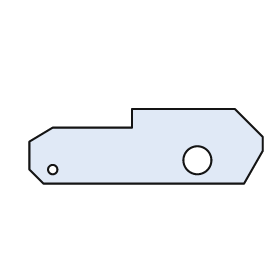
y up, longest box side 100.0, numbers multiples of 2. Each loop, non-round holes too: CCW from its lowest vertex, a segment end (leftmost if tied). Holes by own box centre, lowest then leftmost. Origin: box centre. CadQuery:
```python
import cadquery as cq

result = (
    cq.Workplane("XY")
    .moveTo(-44.0, -16.0)
    .lineTo(42.0, -16.0)
    .lineTo(50.0, -2.0)
    .lineTo(50.0, 4.0)
    .lineTo(38.0, 16.0)
    .lineTo(-6.0, 16.0)
    .lineTo(-6.0, 8.0)
    .lineTo(-40.0, 8.0)
    .lineTo(-50.0, 2.0)
    .lineTo(-50.0, -10.0)
    .close()
    .moveTo(-40.0, -10.0)
    .circle(2.0)
    .moveTo(22.0, -6.0)
    .circle(6.0)
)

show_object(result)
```